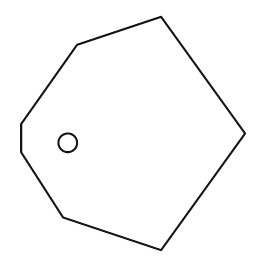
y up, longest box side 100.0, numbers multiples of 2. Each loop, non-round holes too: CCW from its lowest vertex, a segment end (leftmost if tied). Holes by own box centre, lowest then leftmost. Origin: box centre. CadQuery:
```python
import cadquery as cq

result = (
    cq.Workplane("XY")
    .moveTo(12.0, -50.0)
    .lineTo(48.0, 0.0)
    .lineTo(12.0, 50.0)
    .lineTo(-24.0, 38.0)
    .lineTo(-48.0, 4.0)
    .lineTo(-48.0, -8.0)
    .lineTo(-30.0, -36.0)
    .close()
    .moveTo(-28.0, -4.0)
    .circle(4.0)
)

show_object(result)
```